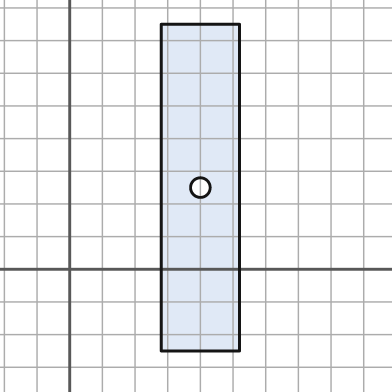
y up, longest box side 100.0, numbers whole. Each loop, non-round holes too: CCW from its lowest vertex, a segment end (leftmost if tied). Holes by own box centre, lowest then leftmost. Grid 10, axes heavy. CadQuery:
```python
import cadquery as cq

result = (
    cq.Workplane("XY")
    .moveTo(28.0, -25.0)
    .lineTo(52.0, -25.0)
    .lineTo(52.0, 75.0)
    .lineTo(28.0, 75.0)
    .close()
    .moveTo(40.0, 25.0)
    .circle(3.0)
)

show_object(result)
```